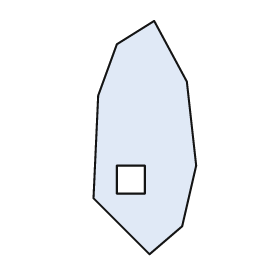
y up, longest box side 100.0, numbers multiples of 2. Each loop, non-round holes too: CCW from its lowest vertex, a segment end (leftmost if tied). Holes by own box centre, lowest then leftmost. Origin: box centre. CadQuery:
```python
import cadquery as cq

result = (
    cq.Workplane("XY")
    .moveTo(2.0, -50.0)
    .lineTo(16.0, -38.0)
    .lineTo(22.0, -12.0)
    .lineTo(18.0, 24.0)
    .lineTo(4.0, 50.0)
    .lineTo(-12.0, 40.0)
    .lineTo(-20.0, 18.0)
    .lineTo(-22.0, -26.0)
    .close()
    .moveTo(-12.0, -24.0)
    .lineTo(0.0, -24.0)
    .lineTo(0.0, -12.0)
    .lineTo(-12.0, -12.0)
    .close()
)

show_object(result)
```